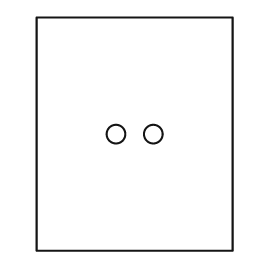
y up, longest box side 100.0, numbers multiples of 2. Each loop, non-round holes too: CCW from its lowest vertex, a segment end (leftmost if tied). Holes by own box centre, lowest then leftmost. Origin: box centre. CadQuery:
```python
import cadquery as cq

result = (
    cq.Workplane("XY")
    .moveTo(-42.0, -50.0)
    .lineTo(42.0, -50.0)
    .lineTo(42.0, 50.0)
    .lineTo(-42.0, 50.0)
    .close()
    .moveTo(-8.0, 0.0)
    .circle(4.0)
    .moveTo(8.0, 0.0)
    .circle(4.0)
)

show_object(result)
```